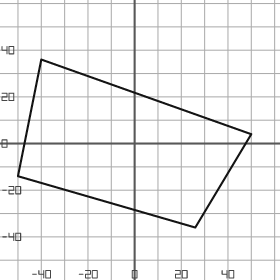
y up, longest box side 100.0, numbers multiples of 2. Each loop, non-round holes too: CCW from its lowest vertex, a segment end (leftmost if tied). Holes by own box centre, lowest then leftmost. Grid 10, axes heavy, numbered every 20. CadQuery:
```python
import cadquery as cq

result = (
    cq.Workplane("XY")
    .moveTo(26.0, -36.0)
    .lineTo(50.0, 4.0)
    .lineTo(-40.0, 36.0)
    .lineTo(-50.0, -14.0)
    .close()
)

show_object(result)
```